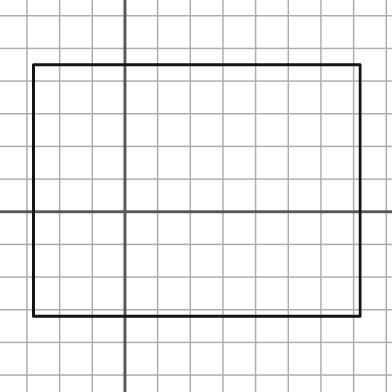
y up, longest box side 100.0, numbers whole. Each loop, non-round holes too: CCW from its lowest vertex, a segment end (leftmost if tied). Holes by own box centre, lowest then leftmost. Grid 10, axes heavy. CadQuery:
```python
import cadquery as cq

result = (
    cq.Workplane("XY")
    .moveTo(-28.0, -32.0)
    .lineTo(72.0, -32.0)
    .lineTo(72.0, 45.0)
    .lineTo(-28.0, 45.0)
    .close()
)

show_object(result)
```